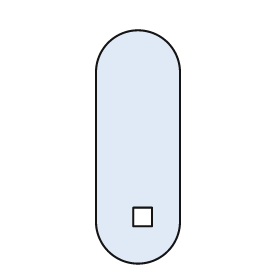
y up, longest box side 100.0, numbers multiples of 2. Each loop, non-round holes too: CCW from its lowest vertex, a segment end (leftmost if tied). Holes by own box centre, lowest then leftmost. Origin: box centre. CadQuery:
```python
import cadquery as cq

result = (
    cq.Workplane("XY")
    .moveTo(-18.0, -32.0)
    .threePointArc((0.0, -50.0), (18.0, -32.0))
    .lineTo(18.0, 32.0)
    .threePointArc((0.0, 50.0), (-18.0, 32.0))
    .close()
    .moveTo(-2.0, -34.0)
    .lineTo(6.0, -34.0)
    .lineTo(6.0, -26.0)
    .lineTo(-2.0, -26.0)
    .close()
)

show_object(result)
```